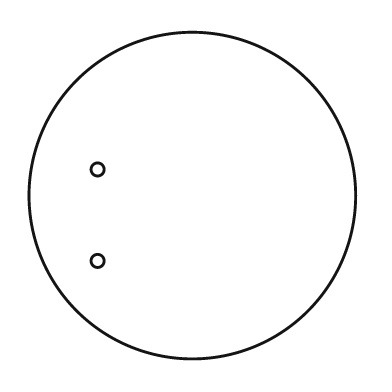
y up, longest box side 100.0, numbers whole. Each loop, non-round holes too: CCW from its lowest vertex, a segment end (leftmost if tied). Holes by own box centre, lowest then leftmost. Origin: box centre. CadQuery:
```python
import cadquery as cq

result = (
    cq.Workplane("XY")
    .moveTo(0.0, 0.0)
    .circle(50.0)
    .moveTo(-29.0, -20.0)
    .circle(2.0)
    .moveTo(-29.0, 8.0)
    .circle(2.0)
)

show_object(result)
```